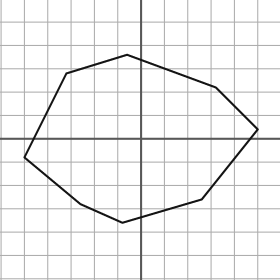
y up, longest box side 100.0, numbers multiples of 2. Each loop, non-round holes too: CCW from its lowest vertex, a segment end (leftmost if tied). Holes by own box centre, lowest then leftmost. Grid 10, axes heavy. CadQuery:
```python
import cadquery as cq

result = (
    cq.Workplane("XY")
    .moveTo(-8.0, -36.0)
    .lineTo(26.0, -26.0)
    .lineTo(50.0, 4.0)
    .lineTo(32.0, 22.0)
    .lineTo(-6.0, 36.0)
    .lineTo(-32.0, 28.0)
    .lineTo(-50.0, -8.0)
    .lineTo(-26.0, -28.0)
    .close()
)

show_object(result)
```